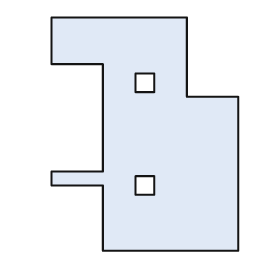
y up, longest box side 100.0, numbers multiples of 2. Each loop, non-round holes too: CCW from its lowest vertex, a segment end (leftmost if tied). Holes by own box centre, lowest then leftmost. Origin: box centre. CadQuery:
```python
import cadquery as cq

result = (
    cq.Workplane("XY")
    .moveTo(-18.0, -50.0)
    .lineTo(40.0, -50.0)
    .lineTo(40.0, 16.0)
    .lineTo(18.0, 16.0)
    .lineTo(18.0, 50.0)
    .lineTo(-40.0, 50.0)
    .lineTo(-40.0, 30.0)
    .lineTo(-18.0, 30.0)
    .lineTo(-18.0, -16.0)
    .lineTo(-40.0, -16.0)
    .lineTo(-40.0, -22.0)
    .lineTo(-18.0, -22.0)
    .close()
    .moveTo(-4.0, -26.0)
    .lineTo(4.0, -26.0)
    .lineTo(4.0, -18.0)
    .lineTo(-4.0, -18.0)
    .close()
    .moveTo(-4.0, 18.0)
    .lineTo(4.0, 18.0)
    .lineTo(4.0, 26.0)
    .lineTo(-4.0, 26.0)
    .close()
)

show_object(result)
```